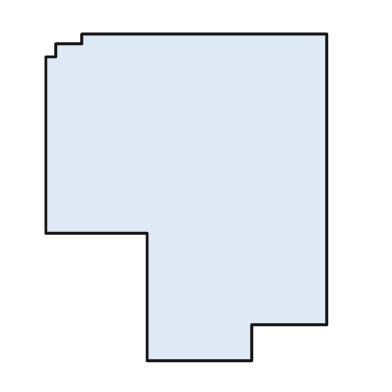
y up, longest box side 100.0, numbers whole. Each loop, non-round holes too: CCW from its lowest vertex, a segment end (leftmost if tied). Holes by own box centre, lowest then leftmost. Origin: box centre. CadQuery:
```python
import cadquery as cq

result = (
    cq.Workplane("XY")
    .moveTo(-12.0, -50.0)
    .lineTo(20.0, -50.0)
    .lineTo(20.0, -39.0)
    .lineTo(43.0, -39.0)
    .lineTo(43.0, 50.0)
    .lineTo(-32.0, 50.0)
    .lineTo(-32.0, 47.0)
    .lineTo(-40.0, 47.0)
    .lineTo(-40.0, 43.0)
    .lineTo(-43.0, 43.0)
    .lineTo(-43.0, -11.0)
    .lineTo(-12.0, -11.0)
    .close()
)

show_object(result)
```